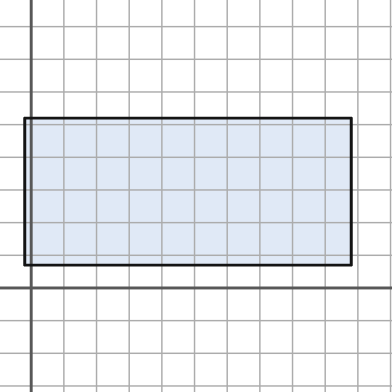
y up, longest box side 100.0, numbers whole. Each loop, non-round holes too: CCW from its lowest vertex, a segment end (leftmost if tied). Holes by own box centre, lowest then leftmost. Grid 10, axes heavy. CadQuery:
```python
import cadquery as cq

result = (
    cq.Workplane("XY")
    .moveTo(-2.0, 7.0)
    .lineTo(98.0, 7.0)
    .lineTo(98.0, 52.0)
    .lineTo(-2.0, 52.0)
    .close()
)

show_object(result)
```